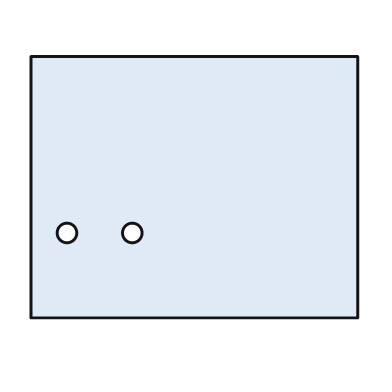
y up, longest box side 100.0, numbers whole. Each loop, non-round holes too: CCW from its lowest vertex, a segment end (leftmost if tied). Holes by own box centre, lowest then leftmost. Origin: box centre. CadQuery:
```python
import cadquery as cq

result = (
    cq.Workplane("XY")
    .moveTo(-50.0, -40.0)
    .lineTo(50.0, -40.0)
    .lineTo(50.0, 40.0)
    .lineTo(-50.0, 40.0)
    .close()
    .moveTo(-39.0, -14.0)
    .circle(3.0)
    .moveTo(-19.0, -14.0)
    .circle(3.0)
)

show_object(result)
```